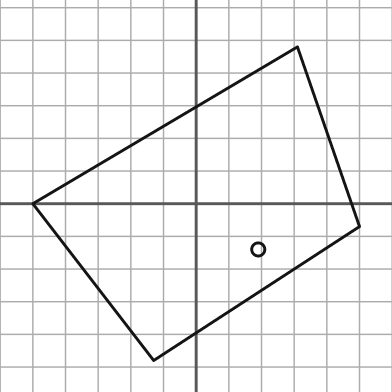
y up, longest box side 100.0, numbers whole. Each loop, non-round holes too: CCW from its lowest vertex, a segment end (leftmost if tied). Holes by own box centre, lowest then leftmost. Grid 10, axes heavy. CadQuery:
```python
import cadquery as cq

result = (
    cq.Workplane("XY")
    .moveTo(-13.0, -48.0)
    .lineTo(50.0, -7.0)
    .lineTo(31.0, 48.0)
    .lineTo(-50.0, 0.0)
    .close()
    .moveTo(19.0, -14.0)
    .circle(2.0)
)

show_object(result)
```